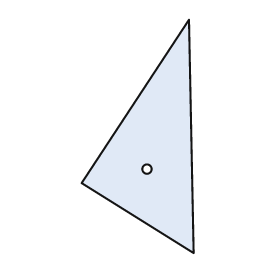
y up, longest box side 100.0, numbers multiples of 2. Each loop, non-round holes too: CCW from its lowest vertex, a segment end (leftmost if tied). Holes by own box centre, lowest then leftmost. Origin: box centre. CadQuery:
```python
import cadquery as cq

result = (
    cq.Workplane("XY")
    .moveTo(24.0, -50.0)
    .lineTo(22.0, 50.0)
    .lineTo(-24.0, -20.0)
    .close()
    .moveTo(4.0, -14.0)
    .circle(2.0)
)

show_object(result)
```